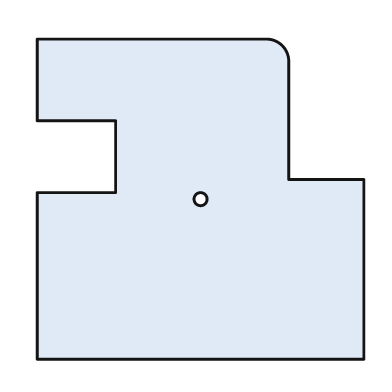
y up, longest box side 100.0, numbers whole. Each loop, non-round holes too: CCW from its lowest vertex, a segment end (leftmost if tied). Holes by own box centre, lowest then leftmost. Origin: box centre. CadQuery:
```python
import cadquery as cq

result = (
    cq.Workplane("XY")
    .moveTo(-50.0, -49.0)
    .lineTo(50.0, -49.0)
    .lineTo(50.0, 6.0)
    .lineTo(27.0, 6.0)
    .lineTo(27.0, 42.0)
    .threePointArc((25.0, 47.0), (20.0, 49.0))
    .lineTo(-50.0, 49.0)
    .lineTo(-50.0, 24.0)
    .lineTo(-26.0, 24.0)
    .lineTo(-26.0, 2.0)
    .lineTo(-50.0, 2.0)
    .close()
    .moveTo(0.0, 0.0)
    .circle(2.0)
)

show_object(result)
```